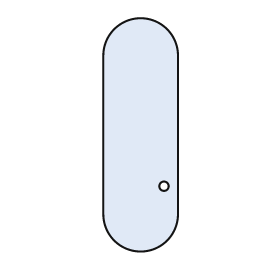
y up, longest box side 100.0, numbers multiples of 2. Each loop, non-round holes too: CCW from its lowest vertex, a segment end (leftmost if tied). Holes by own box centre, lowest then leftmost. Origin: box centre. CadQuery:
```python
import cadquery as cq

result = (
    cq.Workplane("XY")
    .moveTo(-16.0, -34.0)
    .threePointArc((0.0, -50.0), (16.0, -34.0))
    .lineTo(16.0, 34.0)
    .threePointArc((0.0, 50.0), (-16.0, 34.0))
    .close()
    .moveTo(10.0, -22.0)
    .circle(2.0)
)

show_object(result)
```